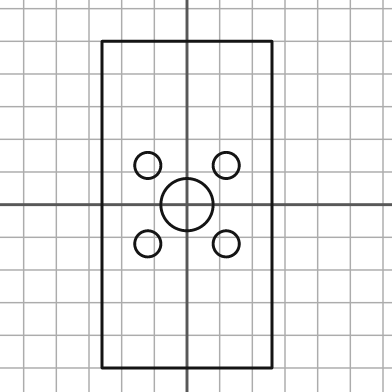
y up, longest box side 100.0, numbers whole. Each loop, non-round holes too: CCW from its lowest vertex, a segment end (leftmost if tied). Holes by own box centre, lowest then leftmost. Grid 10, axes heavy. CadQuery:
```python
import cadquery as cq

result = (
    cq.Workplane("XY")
    .moveTo(-26.0, -50.0)
    .lineTo(26.0, -50.0)
    .lineTo(26.0, 50.0)
    .lineTo(-26.0, 50.0)
    .close()
    .moveTo(-12.0, -12.0)
    .circle(4.0)
    .moveTo(12.0, -12.0)
    .circle(4.0)
    .moveTo(0.0, 0.0)
    .circle(8.0)
    .moveTo(-12.0, 12.0)
    .circle(4.0)
    .moveTo(12.0, 12.0)
    .circle(4.0)
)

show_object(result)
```